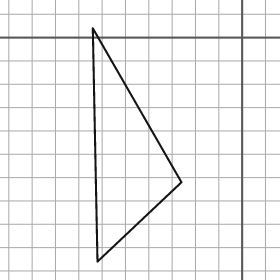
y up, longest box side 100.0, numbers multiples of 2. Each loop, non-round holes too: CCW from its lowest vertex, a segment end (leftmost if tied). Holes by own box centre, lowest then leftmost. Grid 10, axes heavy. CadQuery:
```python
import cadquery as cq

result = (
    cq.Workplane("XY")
    .moveTo(-62.0, -96.0)
    .lineTo(-26.0, -62.0)
    .lineTo(-64.0, 4.0)
    .close()
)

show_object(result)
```